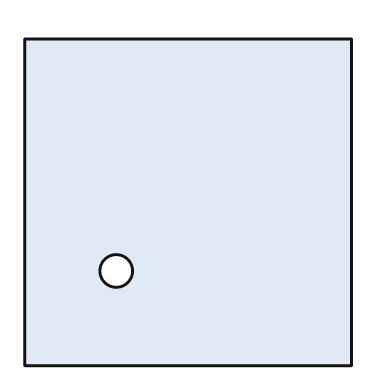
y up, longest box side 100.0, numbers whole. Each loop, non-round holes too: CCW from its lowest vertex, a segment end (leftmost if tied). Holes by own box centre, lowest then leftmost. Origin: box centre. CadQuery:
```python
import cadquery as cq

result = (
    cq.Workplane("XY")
    .moveTo(-50.0, -50.0)
    .lineTo(50.0, -50.0)
    .lineTo(50.0, 50.0)
    .lineTo(-50.0, 50.0)
    .close()
    .moveTo(-22.0, -21.0)
    .circle(5.0)
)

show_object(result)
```